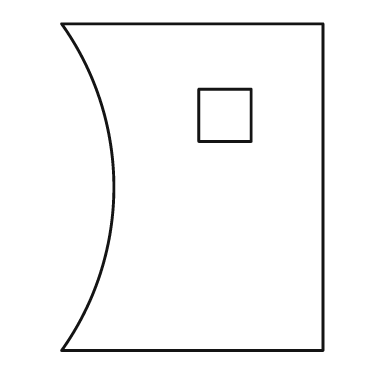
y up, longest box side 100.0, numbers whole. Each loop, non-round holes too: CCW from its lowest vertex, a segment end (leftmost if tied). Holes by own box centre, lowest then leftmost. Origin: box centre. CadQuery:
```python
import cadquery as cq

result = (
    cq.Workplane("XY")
    .moveTo(-40.0, -50.0)
    .lineTo(40.0, -50.0)
    .lineTo(40.0, 50.0)
    .lineTo(-40.0, 50.0)
    .threePointArc((-24.0, 0.0), (-40.0, -50.0))
    .close()
    .moveTo(2.0, 14.0)
    .lineTo(18.0, 14.0)
    .lineTo(18.0, 30.0)
    .lineTo(2.0, 30.0)
    .close()
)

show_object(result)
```